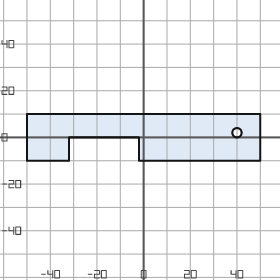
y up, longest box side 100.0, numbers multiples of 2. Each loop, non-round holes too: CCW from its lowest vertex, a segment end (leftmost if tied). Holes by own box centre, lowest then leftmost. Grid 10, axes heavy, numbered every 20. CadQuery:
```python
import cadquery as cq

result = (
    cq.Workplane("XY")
    .moveTo(-50.0, -10.0)
    .lineTo(-32.0, -10.0)
    .lineTo(-32.0, 0.0)
    .lineTo(-2.0, 0.0)
    .lineTo(-2.0, -10.0)
    .lineTo(50.0, -10.0)
    .lineTo(50.0, 10.0)
    .lineTo(-50.0, 10.0)
    .close()
    .moveTo(40.0, 2.0)
    .circle(2.0)
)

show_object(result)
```